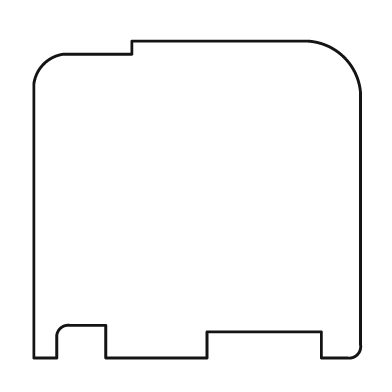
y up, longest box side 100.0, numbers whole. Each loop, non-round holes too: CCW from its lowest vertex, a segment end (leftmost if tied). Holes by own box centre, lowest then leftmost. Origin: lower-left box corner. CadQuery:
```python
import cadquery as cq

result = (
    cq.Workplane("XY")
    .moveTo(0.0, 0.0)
    .lineTo(7.0, 0.0)
    .lineTo(7.0, 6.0)
    .threePointArc((8.0, 9.0), (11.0, 10.0))
    .lineTo(22.0, 10.0)
    .lineTo(22.0, 0.0)
    .lineTo(53.0, 0.0)
    .lineTo(53.0, 8.0)
    .lineTo(88.0, 8.0)
    .lineTo(88.0, 0.0)
    .lineTo(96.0, 0.0)
    .threePointArc((99.0, 1.0), (100.0, 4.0))
    .lineTo(100.0, 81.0)
    .threePointArc((95.0, 92.0), (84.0, 97.0))
    .lineTo(30.0, 97.0)
    .lineTo(30.0, 93.0)
    .lineTo(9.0, 93.0)
    .threePointArc((3.0, 90.0), (0.0, 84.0))
    .close()
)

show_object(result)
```